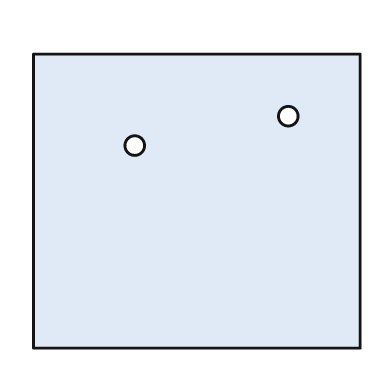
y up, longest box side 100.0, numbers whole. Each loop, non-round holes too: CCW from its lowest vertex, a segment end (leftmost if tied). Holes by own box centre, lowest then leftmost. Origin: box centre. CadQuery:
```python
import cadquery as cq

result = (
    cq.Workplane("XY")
    .moveTo(-50.0, -45.0)
    .lineTo(50.0, -45.0)
    .lineTo(50.0, 45.0)
    .lineTo(-50.0, 45.0)
    .close()
    .moveTo(-19.0, 17.0)
    .circle(3.0)
    .moveTo(28.0, 26.0)
    .circle(3.0)
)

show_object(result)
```